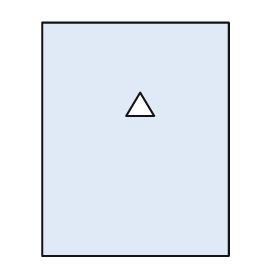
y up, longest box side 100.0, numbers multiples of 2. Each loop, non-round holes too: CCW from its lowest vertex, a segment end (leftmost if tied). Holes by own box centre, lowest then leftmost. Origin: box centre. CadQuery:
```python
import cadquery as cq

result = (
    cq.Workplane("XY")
    .moveTo(-40.0, -50.0)
    .lineTo(40.0, -50.0)
    .lineTo(40.0, 50.0)
    .lineTo(-40.0, 50.0)
    .close()
    .moveTo(-4.0, 10.0)
    .lineTo(8.0, 10.0)
    .lineTo(2.0, 20.0)
    .close()
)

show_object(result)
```